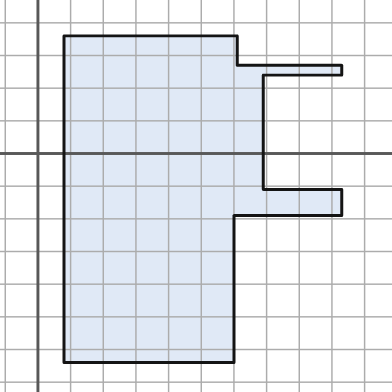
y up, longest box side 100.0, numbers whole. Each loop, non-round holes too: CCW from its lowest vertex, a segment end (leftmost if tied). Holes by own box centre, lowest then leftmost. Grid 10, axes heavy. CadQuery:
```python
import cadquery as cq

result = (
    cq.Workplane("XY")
    .moveTo(8.0, -64.0)
    .lineTo(60.0, -64.0)
    .lineTo(60.0, -19.0)
    .lineTo(93.0, -19.0)
    .lineTo(93.0, -11.0)
    .lineTo(69.0, -11.0)
    .lineTo(69.0, 24.0)
    .lineTo(93.0, 24.0)
    .lineTo(93.0, 27.0)
    .lineTo(61.0, 27.0)
    .lineTo(61.0, 36.0)
    .lineTo(8.0, 36.0)
    .close()
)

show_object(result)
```